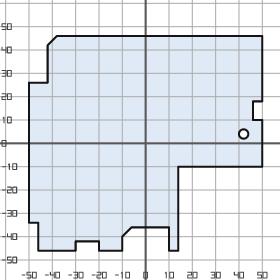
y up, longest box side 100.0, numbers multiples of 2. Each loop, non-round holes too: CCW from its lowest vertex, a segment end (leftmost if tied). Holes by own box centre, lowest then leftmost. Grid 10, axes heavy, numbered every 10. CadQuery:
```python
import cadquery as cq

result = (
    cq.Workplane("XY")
    .moveTo(-46.0, -46.0)
    .lineTo(-30.0, -46.0)
    .lineTo(-30.0, -42.0)
    .lineTo(-20.0, -42.0)
    .lineTo(-20.0, -46.0)
    .lineTo(-10.0, -46.0)
    .lineTo(-10.0, -40.0)
    .lineTo(-6.0, -36.0)
    .lineTo(10.0, -36.0)
    .lineTo(10.0, -46.0)
    .lineTo(14.0, -46.0)
    .lineTo(14.0, -10.0)
    .lineTo(50.0, -10.0)
    .lineTo(50.0, 10.0)
    .lineTo(46.0, 10.0)
    .lineTo(46.0, 18.0)
    .lineTo(50.0, 18.0)
    .lineTo(50.0, 46.0)
    .lineTo(-38.0, 46.0)
    .lineTo(-42.0, 42.0)
    .lineTo(-42.0, 26.0)
    .lineTo(-50.0, 26.0)
    .lineTo(-50.0, -34.0)
    .lineTo(-46.0, -34.0)
    .close()
    .moveTo(42.0, 4.0)
    .circle(2.0)
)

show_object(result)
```